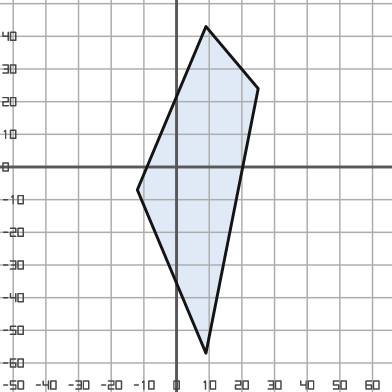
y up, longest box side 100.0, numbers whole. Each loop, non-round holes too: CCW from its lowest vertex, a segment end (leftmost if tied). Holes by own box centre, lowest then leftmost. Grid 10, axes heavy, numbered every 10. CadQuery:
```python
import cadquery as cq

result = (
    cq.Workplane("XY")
    .moveTo(9.0, -57.0)
    .lineTo(25.0, 24.0)
    .lineTo(9.0, 43.0)
    .lineTo(-12.0, -7.0)
    .close()
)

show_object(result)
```